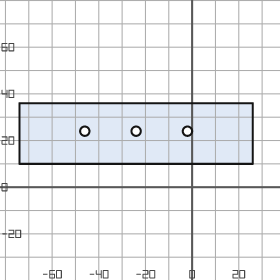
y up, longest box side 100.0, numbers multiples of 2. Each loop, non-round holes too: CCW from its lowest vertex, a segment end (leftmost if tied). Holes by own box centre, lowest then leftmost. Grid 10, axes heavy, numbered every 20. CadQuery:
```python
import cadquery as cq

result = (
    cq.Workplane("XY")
    .moveTo(-74.0, 10.0)
    .lineTo(26.0, 10.0)
    .lineTo(26.0, 36.0)
    .lineTo(-74.0, 36.0)
    .close()
    .moveTo(-46.0, 24.0)
    .circle(2.0)
    .moveTo(-24.0, 24.0)
    .circle(2.0)
    .moveTo(-2.0, 24.0)
    .circle(2.0)
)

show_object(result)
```